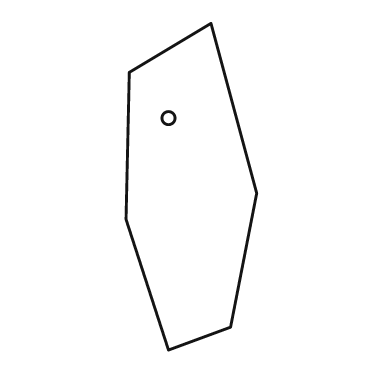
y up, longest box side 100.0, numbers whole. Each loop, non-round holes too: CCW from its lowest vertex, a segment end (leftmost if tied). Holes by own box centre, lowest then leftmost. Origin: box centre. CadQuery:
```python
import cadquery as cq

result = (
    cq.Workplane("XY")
    .moveTo(-7.0, -50.0)
    .lineTo(12.0, -43.0)
    .lineTo(20.0, -2.0)
    .lineTo(6.0, 50.0)
    .lineTo(-19.0, 35.0)
    .lineTo(-20.0, -10.0)
    .close()
    .moveTo(-7.0, 21.0)
    .circle(2.0)
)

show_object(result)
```